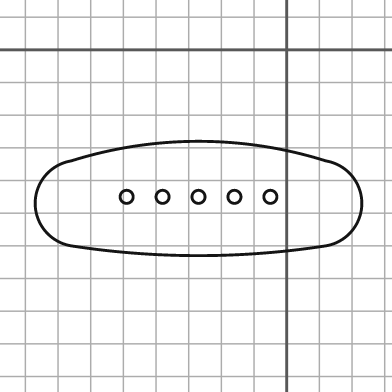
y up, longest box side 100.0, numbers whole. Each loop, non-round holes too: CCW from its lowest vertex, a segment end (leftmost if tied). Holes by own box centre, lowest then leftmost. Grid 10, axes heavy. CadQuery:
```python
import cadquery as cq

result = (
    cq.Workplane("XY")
    .moveTo(-66.0, -60.0)
    .threePointArc((-27.0, -63.0), (12.0, -60.0))
    .threePointArc((23.0, -47.0), (12.0, -34.0))
    .threePointArc((-27.0, -28.0), (-66.0, -34.0))
    .threePointArc((-77.0, -47.0), (-66.0, -60.0))
    .close()
    .moveTo(-49.0, -45.0)
    .circle(2.0)
    .moveTo(-38.0, -45.0)
    .circle(2.0)
    .moveTo(-27.0, -45.0)
    .circle(2.0)
    .moveTo(-16.0, -45.0)
    .circle(2.0)
    .moveTo(-5.0, -45.0)
    .circle(2.0)
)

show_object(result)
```